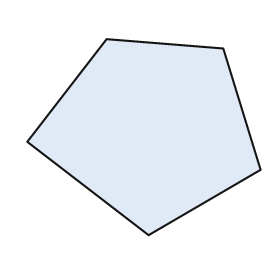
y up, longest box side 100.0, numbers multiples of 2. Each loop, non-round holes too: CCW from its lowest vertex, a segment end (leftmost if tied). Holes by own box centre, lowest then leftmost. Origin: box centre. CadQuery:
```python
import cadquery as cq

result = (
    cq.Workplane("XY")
    .moveTo(2.0, -42.0)
    .lineTo(50.0, -14.0)
    .lineTo(34.0, 38.0)
    .lineTo(-16.0, 42.0)
    .lineTo(-50.0, -2.0)
    .close()
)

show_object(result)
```